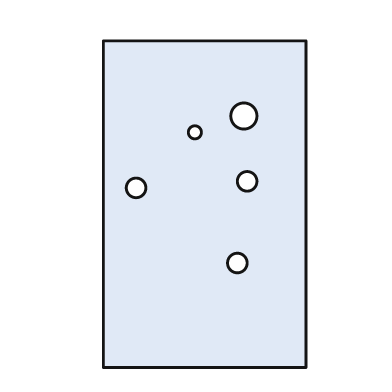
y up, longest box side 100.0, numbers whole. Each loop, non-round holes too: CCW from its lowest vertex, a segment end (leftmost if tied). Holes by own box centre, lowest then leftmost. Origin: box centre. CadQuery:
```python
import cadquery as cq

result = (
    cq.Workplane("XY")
    .moveTo(-31.0, -50.0)
    .lineTo(31.0, -50.0)
    .lineTo(31.0, 50.0)
    .lineTo(-31.0, 50.0)
    .close()
    .moveTo(10.0, -18.0)
    .circle(3.0)
    .moveTo(-21.0, 5.0)
    .circle(3.0)
    .moveTo(13.0, 7.0)
    .circle(3.0)
    .moveTo(-3.0, 22.0)
    .circle(2.0)
    .moveTo(12.0, 27.0)
    .circle(4.0)
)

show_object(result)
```